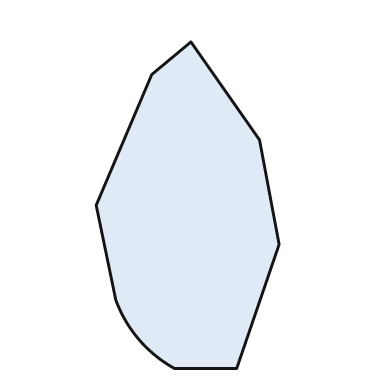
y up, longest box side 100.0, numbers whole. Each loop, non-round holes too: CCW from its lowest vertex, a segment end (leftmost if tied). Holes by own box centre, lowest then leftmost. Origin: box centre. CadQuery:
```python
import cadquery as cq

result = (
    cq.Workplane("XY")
    .moveTo(-4.0, -50.0)
    .lineTo(15.0, -50.0)
    .lineTo(28.0, -12.0)
    .lineTo(22.0, 20.0)
    .lineTo(1.0, 50.0)
    .lineTo(-11.0, 40.0)
    .lineTo(-28.0, 0.0)
    .lineTo(-22.0, -29.0)
    .threePointArc((-15.0, -41.0), (-4.0, -50.0))
    .close()
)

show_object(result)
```